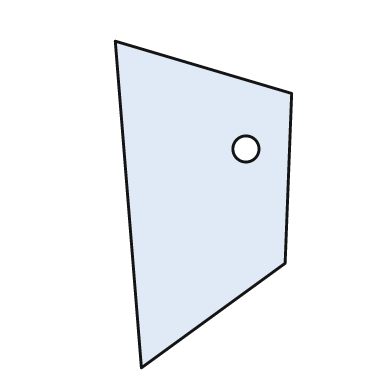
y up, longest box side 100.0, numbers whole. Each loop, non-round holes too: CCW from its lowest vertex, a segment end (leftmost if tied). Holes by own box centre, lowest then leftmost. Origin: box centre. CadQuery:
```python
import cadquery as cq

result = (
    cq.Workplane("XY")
    .moveTo(-19.0, -50.0)
    .lineTo(25.0, -18.0)
    .lineTo(27.0, 34.0)
    .lineTo(-27.0, 50.0)
    .close()
    .moveTo(13.0, 17.0)
    .circle(4.0)
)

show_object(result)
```